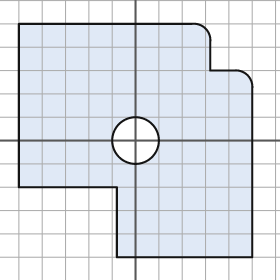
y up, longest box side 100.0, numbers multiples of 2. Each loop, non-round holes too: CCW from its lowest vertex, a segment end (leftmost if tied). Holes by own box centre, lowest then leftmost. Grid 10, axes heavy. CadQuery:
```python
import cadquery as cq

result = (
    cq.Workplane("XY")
    .moveTo(-8.0, -50.0)
    .lineTo(50.0, -50.0)
    .lineTo(50.0, 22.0)
    .threePointArc((48.0, 28.0), (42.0, 30.0))
    .lineTo(32.0, 30.0)
    .lineTo(32.0, 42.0)
    .threePointArc((30.0, 48.0), (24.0, 50.0))
    .lineTo(-50.0, 50.0)
    .lineTo(-50.0, -20.0)
    .lineTo(-8.0, -20.0)
    .close()
    .moveTo(0.0, 0.0)
    .circle(10.0)
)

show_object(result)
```